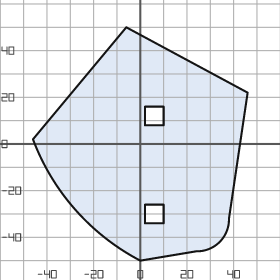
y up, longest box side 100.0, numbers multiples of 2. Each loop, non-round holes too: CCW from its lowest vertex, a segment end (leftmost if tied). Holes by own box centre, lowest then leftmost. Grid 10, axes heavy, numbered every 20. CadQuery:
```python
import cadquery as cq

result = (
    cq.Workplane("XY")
    .moveTo(0.0, -50.0)
    .lineTo(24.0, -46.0)
    .threePointArc((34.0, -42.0), (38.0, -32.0))
    .lineTo(46.0, 22.0)
    .lineTo(-6.0, 50.0)
    .lineTo(-46.0, 2.0)
    .threePointArc((-28.0, -28.0), (0.0, -50.0))
    .close()
    .moveTo(2.0, -34.0)
    .lineTo(10.0, -34.0)
    .lineTo(10.0, -26.0)
    .lineTo(2.0, -26.0)
    .close()
    .moveTo(2.0, 8.0)
    .lineTo(10.0, 8.0)
    .lineTo(10.0, 16.0)
    .lineTo(2.0, 16.0)
    .close()
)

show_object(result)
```